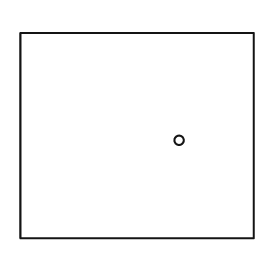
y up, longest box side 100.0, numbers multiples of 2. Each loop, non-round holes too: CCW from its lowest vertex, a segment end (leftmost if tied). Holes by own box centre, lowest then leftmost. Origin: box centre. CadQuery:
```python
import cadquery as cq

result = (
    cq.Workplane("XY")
    .moveTo(-50.0, -44.0)
    .lineTo(50.0, -44.0)
    .lineTo(50.0, 44.0)
    .lineTo(-50.0, 44.0)
    .close()
    .moveTo(18.0, -2.0)
    .circle(2.0)
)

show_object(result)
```